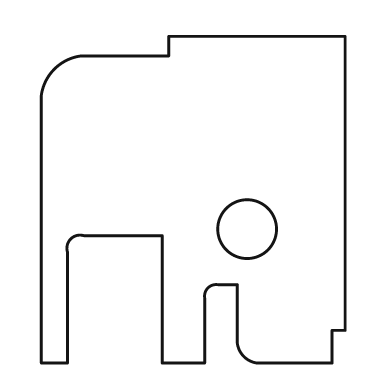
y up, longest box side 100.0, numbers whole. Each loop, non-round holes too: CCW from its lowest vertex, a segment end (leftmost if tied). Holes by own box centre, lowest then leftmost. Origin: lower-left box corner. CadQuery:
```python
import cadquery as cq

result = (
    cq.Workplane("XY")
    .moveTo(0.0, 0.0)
    .lineTo(8.0, 0.0)
    .lineTo(8.0, 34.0)
    .threePointArc((9.0, 38.0), (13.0, 39.0))
    .lineTo(37.0, 39.0)
    .lineTo(37.0, 0.0)
    .lineTo(50.0, 0.0)
    .lineTo(50.0, 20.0)
    .threePointArc((51.0, 23.0), (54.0, 24.0))
    .lineTo(60.0, 24.0)
    .lineTo(60.0, 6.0)
    .threePointArc((62.0, 2.0), (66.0, 0.0))
    .lineTo(89.0, 0.0)
    .lineTo(89.0, 10.0)
    .lineTo(93.0, 10.0)
    .lineTo(93.0, 100.0)
    .lineTo(39.0, 100.0)
    .lineTo(39.0, 94.0)
    .lineTo(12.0, 94.0)
    .threePointArc((4.0, 90.0), (0.0, 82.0))
    .close()
    .moveTo(63.0, 41.0)
    .circle(9.0)
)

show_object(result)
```